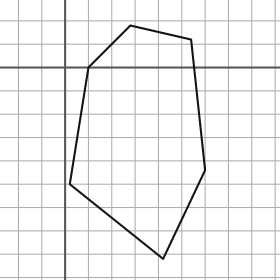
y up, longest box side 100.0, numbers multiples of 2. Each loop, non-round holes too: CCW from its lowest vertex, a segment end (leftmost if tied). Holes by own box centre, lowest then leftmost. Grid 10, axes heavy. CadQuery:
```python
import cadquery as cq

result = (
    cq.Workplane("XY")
    .moveTo(42.0, -82.0)
    .lineTo(60.0, -44.0)
    .lineTo(54.0, 12.0)
    .lineTo(28.0, 18.0)
    .lineTo(10.0, 0.0)
    .lineTo(2.0, -50.0)
    .close()
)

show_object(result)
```